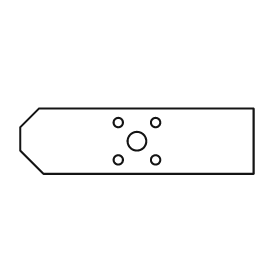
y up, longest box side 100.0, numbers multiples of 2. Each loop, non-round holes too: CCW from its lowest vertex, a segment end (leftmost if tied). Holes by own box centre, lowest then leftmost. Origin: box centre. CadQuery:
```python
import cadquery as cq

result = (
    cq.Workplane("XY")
    .moveTo(-40.0, -14.0)
    .lineTo(50.0, -14.0)
    .lineTo(50.0, 14.0)
    .lineTo(-42.0, 14.0)
    .lineTo(-50.0, 6.0)
    .lineTo(-50.0, -4.0)
    .close()
    .moveTo(-8.0, -8.0)
    .circle(2.0)
    .moveTo(8.0, -8.0)
    .circle(2.0)
    .moveTo(0.0, 0.0)
    .circle(4.0)
    .moveTo(-8.0, 8.0)
    .circle(2.0)
    .moveTo(8.0, 8.0)
    .circle(2.0)
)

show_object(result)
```